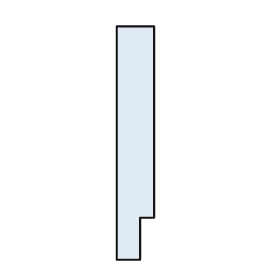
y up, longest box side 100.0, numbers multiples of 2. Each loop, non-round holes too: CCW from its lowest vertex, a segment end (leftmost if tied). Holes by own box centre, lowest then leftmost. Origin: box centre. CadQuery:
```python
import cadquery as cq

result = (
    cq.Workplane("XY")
    .moveTo(-8.0, -50.0)
    .lineTo(2.0, -50.0)
    .lineTo(2.0, -32.0)
    .lineTo(8.0, -32.0)
    .lineTo(8.0, 50.0)
    .lineTo(-8.0, 50.0)
    .close()
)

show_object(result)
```